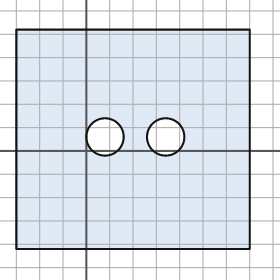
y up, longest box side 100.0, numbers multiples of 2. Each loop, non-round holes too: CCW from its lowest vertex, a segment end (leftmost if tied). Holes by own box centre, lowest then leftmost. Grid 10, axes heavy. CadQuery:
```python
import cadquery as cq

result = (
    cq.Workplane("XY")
    .moveTo(-30.0, -42.0)
    .lineTo(70.0, -42.0)
    .lineTo(70.0, 52.0)
    .lineTo(-30.0, 52.0)
    .close()
    .moveTo(8.0, 6.0)
    .circle(8.0)
    .moveTo(34.0, 6.0)
    .circle(8.0)
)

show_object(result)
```